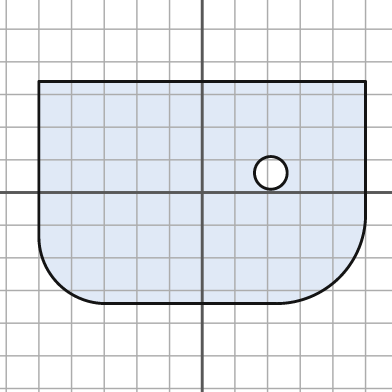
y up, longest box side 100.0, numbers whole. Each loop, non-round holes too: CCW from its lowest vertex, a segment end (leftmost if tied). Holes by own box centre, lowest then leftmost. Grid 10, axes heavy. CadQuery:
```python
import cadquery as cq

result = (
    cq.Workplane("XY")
    .moveTo(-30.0, -34.0)
    .lineTo(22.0, -34.0)
    .threePointArc((42.0, -26.0), (50.0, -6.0))
    .lineTo(50.0, 34.0)
    .lineTo(-50.0, 34.0)
    .lineTo(-50.0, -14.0)
    .threePointArc((-44.0, -28.0), (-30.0, -34.0))
    .close()
    .moveTo(21.0, 6.0)
    .circle(5.0)
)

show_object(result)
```